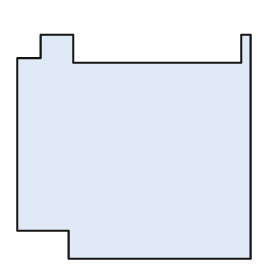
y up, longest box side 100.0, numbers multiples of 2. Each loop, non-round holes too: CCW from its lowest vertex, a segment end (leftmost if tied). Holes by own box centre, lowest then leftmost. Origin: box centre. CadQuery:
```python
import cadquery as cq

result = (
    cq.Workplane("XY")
    .moveTo(-28.0, -48.0)
    .lineTo(50.0, -48.0)
    .lineTo(50.0, 48.0)
    .lineTo(46.0, 48.0)
    .lineTo(46.0, 36.0)
    .lineTo(-26.0, 36.0)
    .lineTo(-26.0, 48.0)
    .lineTo(-40.0, 48.0)
    .lineTo(-40.0, 38.0)
    .lineTo(-50.0, 38.0)
    .lineTo(-50.0, -36.0)
    .lineTo(-28.0, -36.0)
    .close()
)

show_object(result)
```